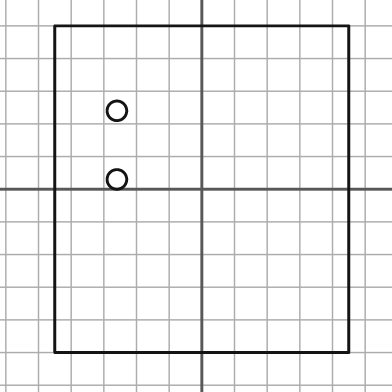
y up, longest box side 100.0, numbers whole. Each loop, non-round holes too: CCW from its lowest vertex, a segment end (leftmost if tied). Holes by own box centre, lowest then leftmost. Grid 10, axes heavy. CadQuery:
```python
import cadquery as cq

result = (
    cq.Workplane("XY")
    .moveTo(-45.0, -50.0)
    .lineTo(45.0, -50.0)
    .lineTo(45.0, 50.0)
    .lineTo(-45.0, 50.0)
    .close()
    .moveTo(-26.0, 3.0)
    .circle(3.0)
    .moveTo(-26.0, 24.0)
    .circle(3.0)
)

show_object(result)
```